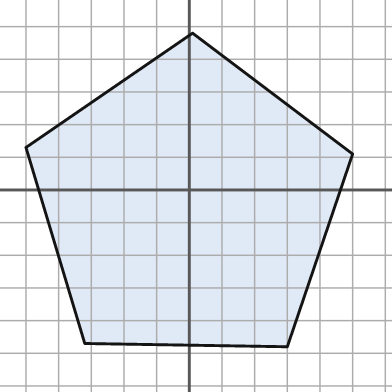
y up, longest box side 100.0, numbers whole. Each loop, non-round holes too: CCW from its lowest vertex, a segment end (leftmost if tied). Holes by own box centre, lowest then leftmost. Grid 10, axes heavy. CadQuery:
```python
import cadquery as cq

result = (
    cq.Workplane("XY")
    .moveTo(30.0, -48.0)
    .lineTo(50.0, 11.0)
    .lineTo(1.0, 48.0)
    .lineTo(-50.0, 13.0)
    .lineTo(-32.0, -47.0)
    .close()
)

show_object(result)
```